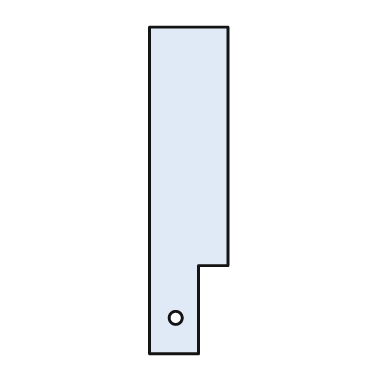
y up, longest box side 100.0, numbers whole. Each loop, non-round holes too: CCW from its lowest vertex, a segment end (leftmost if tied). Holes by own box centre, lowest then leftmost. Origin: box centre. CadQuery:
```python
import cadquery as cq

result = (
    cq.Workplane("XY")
    .moveTo(-12.0, -50.0)
    .lineTo(3.0, -50.0)
    .lineTo(3.0, -23.0)
    .lineTo(12.0, -23.0)
    .lineTo(12.0, 50.0)
    .lineTo(-12.0, 50.0)
    .close()
    .moveTo(-4.0, -39.0)
    .circle(2.0)
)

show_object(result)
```